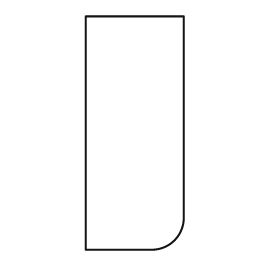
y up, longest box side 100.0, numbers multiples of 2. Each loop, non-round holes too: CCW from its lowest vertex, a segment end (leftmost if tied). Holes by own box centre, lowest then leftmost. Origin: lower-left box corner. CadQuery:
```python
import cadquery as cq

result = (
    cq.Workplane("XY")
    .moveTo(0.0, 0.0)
    .lineTo(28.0, 0.0)
    .threePointArc((38.0, 4.0), (42.0, 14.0))
    .lineTo(42.0, 100.0)
    .lineTo(0.0, 100.0)
    .close()
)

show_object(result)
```